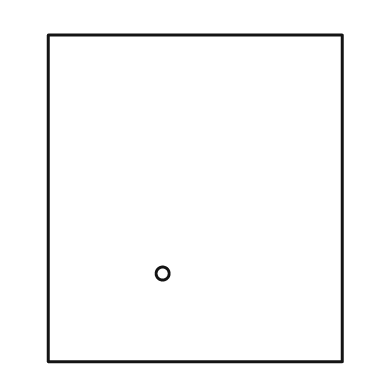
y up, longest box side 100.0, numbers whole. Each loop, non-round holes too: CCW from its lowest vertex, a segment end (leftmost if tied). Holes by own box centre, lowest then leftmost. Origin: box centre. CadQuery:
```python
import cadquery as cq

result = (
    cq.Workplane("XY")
    .moveTo(-45.0, -50.0)
    .lineTo(45.0, -50.0)
    .lineTo(45.0, 50.0)
    .lineTo(-45.0, 50.0)
    .close()
    .moveTo(-10.0, -23.0)
    .circle(2.0)
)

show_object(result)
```